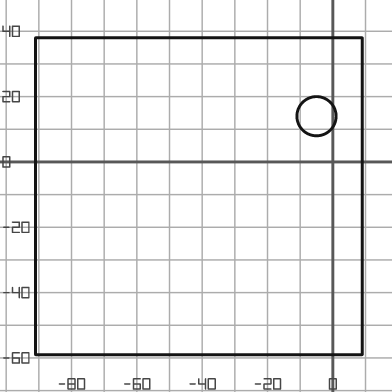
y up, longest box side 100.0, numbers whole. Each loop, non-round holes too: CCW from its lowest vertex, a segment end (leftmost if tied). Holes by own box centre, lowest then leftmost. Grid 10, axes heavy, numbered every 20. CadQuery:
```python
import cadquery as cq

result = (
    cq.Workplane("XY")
    .moveTo(-91.0, -59.0)
    .lineTo(9.0, -59.0)
    .lineTo(9.0, 38.0)
    .lineTo(-91.0, 38.0)
    .close()
    .moveTo(-5.0, 14.0)
    .circle(6.0)
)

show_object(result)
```